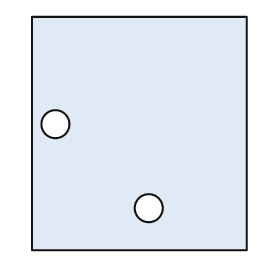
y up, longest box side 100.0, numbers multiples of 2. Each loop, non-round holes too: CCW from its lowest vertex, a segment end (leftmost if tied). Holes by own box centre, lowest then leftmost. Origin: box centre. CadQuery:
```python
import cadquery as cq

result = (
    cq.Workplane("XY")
    .moveTo(-46.0, -50.0)
    .lineTo(46.0, -50.0)
    .lineTo(46.0, 50.0)
    .lineTo(-46.0, 50.0)
    .close()
    .moveTo(4.0, -32.0)
    .circle(6.0)
    .moveTo(-36.0, 4.0)
    .circle(6.0)
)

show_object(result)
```